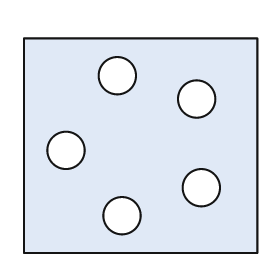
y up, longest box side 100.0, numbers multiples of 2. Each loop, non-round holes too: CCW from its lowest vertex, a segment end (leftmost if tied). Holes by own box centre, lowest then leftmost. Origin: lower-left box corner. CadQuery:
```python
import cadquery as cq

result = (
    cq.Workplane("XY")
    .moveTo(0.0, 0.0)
    .lineTo(100.0, 0.0)
    .lineTo(100.0, 92.0)
    .lineTo(0.0, 92.0)
    .close()
    .moveTo(42.0, 16.0)
    .circle(8.0)
    .moveTo(76.0, 28.0)
    .circle(8.0)
    .moveTo(18.0, 44.0)
    .circle(8.0)
    .moveTo(74.0, 66.0)
    .circle(8.0)
    .moveTo(40.0, 76.0)
    .circle(8.0)
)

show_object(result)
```